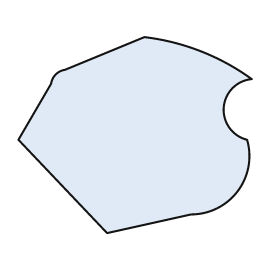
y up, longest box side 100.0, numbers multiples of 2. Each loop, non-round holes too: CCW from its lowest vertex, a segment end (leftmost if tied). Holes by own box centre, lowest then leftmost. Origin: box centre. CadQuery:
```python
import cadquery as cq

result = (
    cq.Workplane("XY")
    .moveTo(-12.0, -42.0)
    .lineTo(24.0, -34.0)
    .threePointArc((44.0, -24.0), (48.0, -2.0))
    .threePointArc((38.0, 12.0), (50.0, 24.0))
    .threePointArc((28.0, 36.0), (4.0, 42.0))
    .lineTo(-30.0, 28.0)
    .threePointArc((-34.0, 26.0), (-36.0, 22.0))
    .lineTo(-50.0, -2.0)
    .close()
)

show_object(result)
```